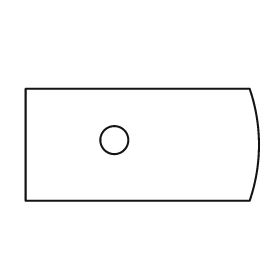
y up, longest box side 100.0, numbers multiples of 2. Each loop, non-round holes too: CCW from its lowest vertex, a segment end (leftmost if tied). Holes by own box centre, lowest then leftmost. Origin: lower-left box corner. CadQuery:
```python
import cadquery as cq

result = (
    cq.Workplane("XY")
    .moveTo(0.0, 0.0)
    .lineTo(96.0, 0.0)
    .threePointArc((100.0, 24.0), (96.0, 48.0))
    .lineTo(0.0, 48.0)
    .close()
    .moveTo(38.0, 26.0)
    .circle(6.0)
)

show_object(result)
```